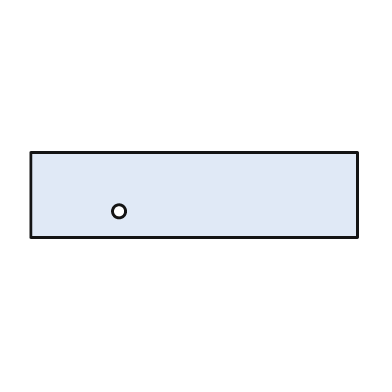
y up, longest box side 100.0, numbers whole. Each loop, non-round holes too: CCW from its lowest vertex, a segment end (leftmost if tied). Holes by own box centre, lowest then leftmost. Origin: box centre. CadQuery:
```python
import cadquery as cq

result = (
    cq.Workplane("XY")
    .moveTo(-50.0, -13.0)
    .lineTo(50.0, -13.0)
    .lineTo(50.0, 13.0)
    .lineTo(-50.0, 13.0)
    .close()
    .moveTo(-23.0, -5.0)
    .circle(2.0)
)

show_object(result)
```